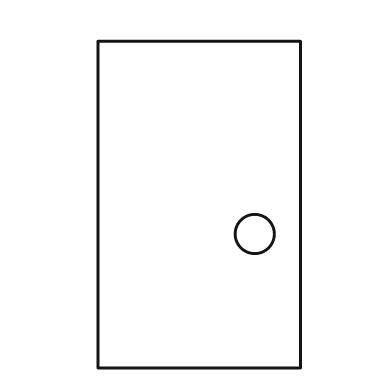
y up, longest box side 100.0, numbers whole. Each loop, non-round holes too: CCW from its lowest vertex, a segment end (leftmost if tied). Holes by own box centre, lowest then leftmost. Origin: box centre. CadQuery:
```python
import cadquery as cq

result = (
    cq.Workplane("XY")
    .moveTo(-31.0, -50.0)
    .lineTo(31.0, -50.0)
    .lineTo(31.0, 50.0)
    .lineTo(-31.0, 50.0)
    .close()
    .moveTo(17.0, -9.0)
    .circle(6.0)
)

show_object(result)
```